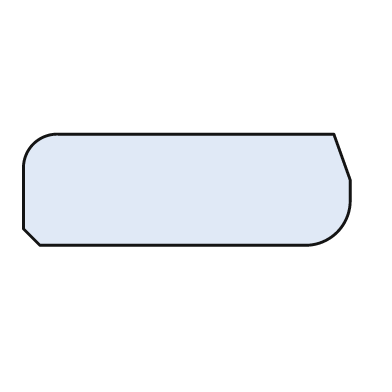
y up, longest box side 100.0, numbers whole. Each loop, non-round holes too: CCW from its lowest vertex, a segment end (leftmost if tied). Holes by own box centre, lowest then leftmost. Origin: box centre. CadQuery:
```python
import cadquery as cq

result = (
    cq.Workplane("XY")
    .moveTo(-45.0, -17.0)
    .lineTo(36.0, -17.0)
    .threePointArc((46.0, -13.0), (50.0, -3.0))
    .lineTo(50.0, 3.0)
    .lineTo(45.0, 17.0)
    .lineTo(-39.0, 17.0)
    .threePointArc((-47.0, 14.0), (-50.0, 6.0))
    .lineTo(-50.0, -12.0)
    .close()
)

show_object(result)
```